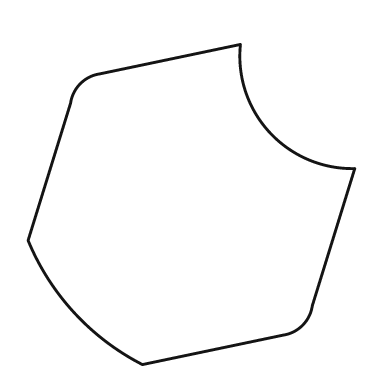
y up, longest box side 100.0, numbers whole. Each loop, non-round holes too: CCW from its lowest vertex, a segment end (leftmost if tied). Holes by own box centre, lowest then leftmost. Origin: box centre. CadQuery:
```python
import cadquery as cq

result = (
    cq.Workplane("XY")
    .moveTo(-15.0, -49.0)
    .lineTo(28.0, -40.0)
    .threePointArc((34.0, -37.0), (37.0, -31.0))
    .lineTo(50.0, 11.0)
    .threePointArc((24.0, 22.0), (15.0, 49.0))
    .lineTo(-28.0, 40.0)
    .threePointArc((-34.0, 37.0), (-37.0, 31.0))
    .lineTo(-50.0, -11.0)
    .threePointArc((-36.0, -33.0), (-15.0, -49.0))
    .close()
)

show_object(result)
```